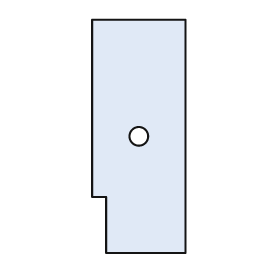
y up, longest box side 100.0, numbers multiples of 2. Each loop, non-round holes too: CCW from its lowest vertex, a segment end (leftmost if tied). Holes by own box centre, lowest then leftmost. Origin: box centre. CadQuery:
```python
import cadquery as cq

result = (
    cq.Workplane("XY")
    .moveTo(-14.0, -50.0)
    .lineTo(20.0, -50.0)
    .lineTo(20.0, 50.0)
    .lineTo(-20.0, 50.0)
    .lineTo(-20.0, -26.0)
    .lineTo(-14.0, -26.0)
    .close()
    .moveTo(0.0, 0.0)
    .circle(4.0)
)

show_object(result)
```